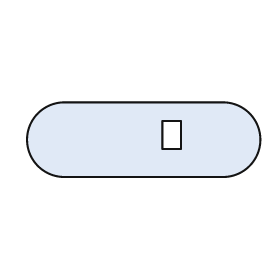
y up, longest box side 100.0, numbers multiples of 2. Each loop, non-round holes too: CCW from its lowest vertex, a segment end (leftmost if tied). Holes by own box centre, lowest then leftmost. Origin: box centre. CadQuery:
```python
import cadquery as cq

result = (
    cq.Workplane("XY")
    .moveTo(-34.0, -16.0)
    .lineTo(34.0, -16.0)
    .threePointArc((50.0, 0.0), (34.0, 16.0))
    .lineTo(-34.0, 16.0)
    .threePointArc((-50.0, 0.0), (-34.0, -16.0))
    .close()
    .moveTo(8.0, -4.0)
    .lineTo(16.0, -4.0)
    .lineTo(16.0, 8.0)
    .lineTo(8.0, 8.0)
    .close()
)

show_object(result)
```